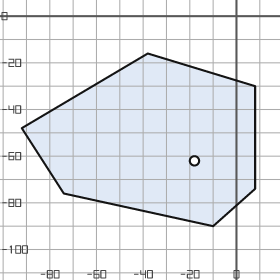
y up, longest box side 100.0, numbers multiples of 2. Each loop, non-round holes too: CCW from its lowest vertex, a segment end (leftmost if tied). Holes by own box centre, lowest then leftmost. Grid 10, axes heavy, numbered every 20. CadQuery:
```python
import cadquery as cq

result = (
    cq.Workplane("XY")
    .moveTo(-10.0, -90.0)
    .lineTo(8.0, -74.0)
    .lineTo(8.0, -30.0)
    .lineTo(-38.0, -16.0)
    .lineTo(-92.0, -48.0)
    .lineTo(-74.0, -76.0)
    .close()
    .moveTo(-18.0, -62.0)
    .circle(2.0)
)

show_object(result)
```